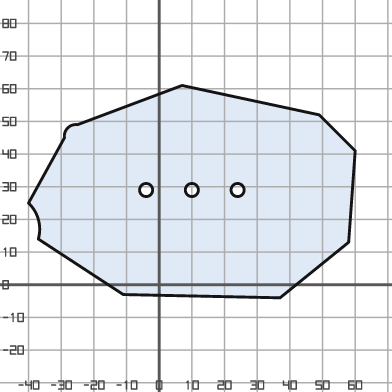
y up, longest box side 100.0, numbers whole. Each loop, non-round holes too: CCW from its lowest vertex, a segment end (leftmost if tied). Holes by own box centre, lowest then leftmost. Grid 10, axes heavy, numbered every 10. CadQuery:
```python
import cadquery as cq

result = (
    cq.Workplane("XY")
    .moveTo(37.0, -4.0)
    .lineTo(58.0, 13.0)
    .lineTo(60.0, 41.0)
    .lineTo(49.0, 52.0)
    .lineTo(7.0, 61.0)
    .lineTo(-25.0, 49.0)
    .threePointArc((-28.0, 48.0), (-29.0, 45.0))
    .lineTo(-40.0, 25.0)
    .threePointArc((-37.0, 20.0), (-37.0, 14.0))
    .lineTo(-11.0, -3.0)
    .close()
    .moveTo(-4.0, 29.0)
    .circle(2.0)
    .moveTo(10.0, 29.0)
    .circle(2.0)
    .moveTo(24.0, 29.0)
    .circle(2.0)
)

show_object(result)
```